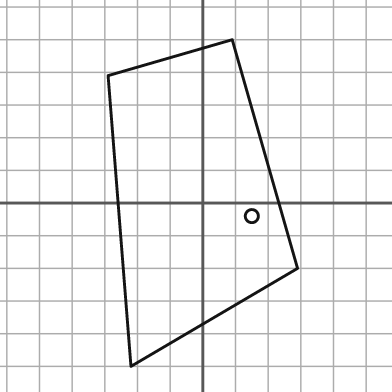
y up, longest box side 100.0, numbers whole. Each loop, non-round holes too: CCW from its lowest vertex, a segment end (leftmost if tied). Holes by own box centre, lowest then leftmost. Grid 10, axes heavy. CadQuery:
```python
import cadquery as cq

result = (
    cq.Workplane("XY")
    .moveTo(-22.0, -50.0)
    .lineTo(29.0, -20.0)
    .lineTo(9.0, 50.0)
    .lineTo(-29.0, 39.0)
    .close()
    .moveTo(15.0, -4.0)
    .circle(2.0)
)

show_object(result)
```